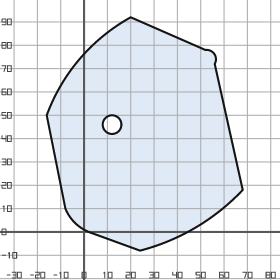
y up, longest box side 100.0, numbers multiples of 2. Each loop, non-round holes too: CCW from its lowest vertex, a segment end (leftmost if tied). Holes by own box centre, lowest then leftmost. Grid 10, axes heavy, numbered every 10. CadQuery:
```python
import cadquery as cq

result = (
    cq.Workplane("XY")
    .moveTo(24.0, -8.0)
    .threePointArc((48.0, 2.0), (68.0, 18.0))
    .lineTo(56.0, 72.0)
    .threePointArc((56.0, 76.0), (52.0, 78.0))
    .lineTo(20.0, 92.0)
    .threePointArc((-2.0, 74.0), (-16.0, 50.0))
    .lineTo(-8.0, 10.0)
    .threePointArc((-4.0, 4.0), (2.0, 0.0))
    .close()
    .moveTo(12.0, 46.0)
    .circle(4.0)
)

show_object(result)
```